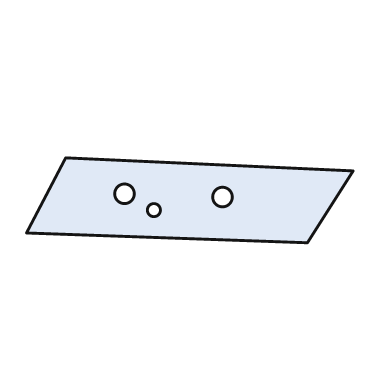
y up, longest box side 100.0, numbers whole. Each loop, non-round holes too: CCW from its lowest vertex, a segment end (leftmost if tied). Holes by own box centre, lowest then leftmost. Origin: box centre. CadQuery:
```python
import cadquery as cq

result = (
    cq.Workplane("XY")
    .moveTo(36.0, -13.0)
    .lineTo(50.0, 9.0)
    .lineTo(-38.0, 13.0)
    .lineTo(-50.0, -10.0)
    .close()
    .moveTo(-11.0, -3.0)
    .circle(2.0)
    .moveTo(10.0, 1.0)
    .circle(3.0)
    .moveTo(-20.0, 2.0)
    .circle(3.0)
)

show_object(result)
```